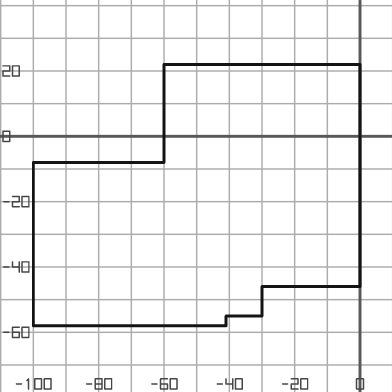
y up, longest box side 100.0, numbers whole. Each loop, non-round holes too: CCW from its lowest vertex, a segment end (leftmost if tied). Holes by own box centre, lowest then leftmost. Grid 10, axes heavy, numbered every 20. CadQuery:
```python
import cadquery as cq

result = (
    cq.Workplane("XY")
    .moveTo(-100.0, -58.0)
    .lineTo(-41.0, -58.0)
    .lineTo(-41.0, -55.0)
    .lineTo(-30.0, -55.0)
    .lineTo(-30.0, -46.0)
    .lineTo(0.0, -46.0)
    .lineTo(0.0, 22.0)
    .lineTo(-60.0, 22.0)
    .lineTo(-60.0, -8.0)
    .lineTo(-100.0, -8.0)
    .close()
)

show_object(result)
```